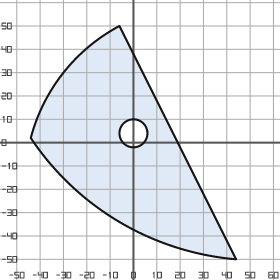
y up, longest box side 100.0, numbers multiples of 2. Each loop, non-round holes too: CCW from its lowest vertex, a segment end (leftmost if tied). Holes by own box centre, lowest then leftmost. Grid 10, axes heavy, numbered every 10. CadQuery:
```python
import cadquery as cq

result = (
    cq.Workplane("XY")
    .moveTo(44.0, -50.0)
    .lineTo(-6.0, 50.0)
    .threePointArc((-30.0, 30.0), (-44.0, 2.0))
    .threePointArc((-6.0, -34.0), (44.0, -50.0))
    .close()
    .moveTo(0.0, 4.0)
    .circle(6.0)
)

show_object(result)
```